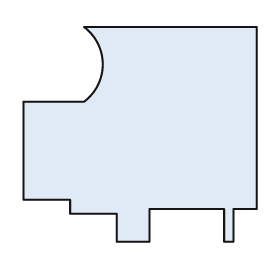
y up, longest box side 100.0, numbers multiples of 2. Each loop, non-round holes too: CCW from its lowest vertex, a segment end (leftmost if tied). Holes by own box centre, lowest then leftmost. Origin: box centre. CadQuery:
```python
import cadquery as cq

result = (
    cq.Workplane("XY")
    .moveTo(-10.0, -46.0)
    .lineTo(4.0, -46.0)
    .lineTo(4.0, -32.0)
    .lineTo(36.0, -32.0)
    .lineTo(36.0, -46.0)
    .lineTo(40.0, -46.0)
    .lineTo(40.0, -32.0)
    .lineTo(50.0, -32.0)
    .lineTo(50.0, 46.0)
    .lineTo(-24.0, 46.0)
    .threePointArc((-16.0, 30.0), (-24.0, 14.0))
    .lineTo(-50.0, 14.0)
    .lineTo(-50.0, -28.0)
    .lineTo(-30.0, -28.0)
    .lineTo(-30.0, -34.0)
    .lineTo(-10.0, -34.0)
    .close()
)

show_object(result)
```